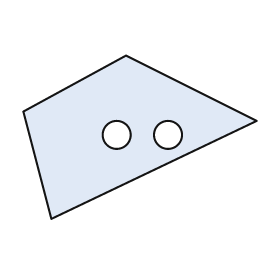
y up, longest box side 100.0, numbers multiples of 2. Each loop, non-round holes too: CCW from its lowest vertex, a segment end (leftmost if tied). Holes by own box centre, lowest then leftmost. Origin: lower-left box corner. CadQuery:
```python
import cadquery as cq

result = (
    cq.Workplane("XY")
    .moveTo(12.0, 0.0)
    .lineTo(100.0, 42.0)
    .lineTo(44.0, 70.0)
    .lineTo(0.0, 46.0)
    .close()
    .moveTo(40.0, 36.0)
    .circle(6.0)
    .moveTo(62.0, 36.0)
    .circle(6.0)
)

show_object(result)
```